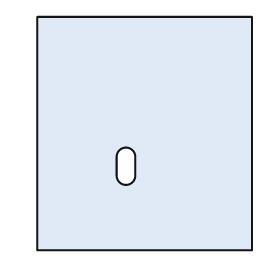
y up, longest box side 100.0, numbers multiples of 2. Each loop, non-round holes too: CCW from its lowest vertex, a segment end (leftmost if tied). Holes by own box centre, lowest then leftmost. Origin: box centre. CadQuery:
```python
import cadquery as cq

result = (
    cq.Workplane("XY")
    .moveTo(-46.0, -50.0)
    .lineTo(46.0, -50.0)
    .lineTo(46.0, 50.0)
    .lineTo(-46.0, 50.0)
    .close()
    .moveTo(-12.0, -18.0)
    .threePointArc((-8.0, -22.0), (-4.0, -18.0))
    .lineTo(-4.0, -10.0)
    .threePointArc((-8.0, -6.0), (-12.0, -10.0))
    .close()
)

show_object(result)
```